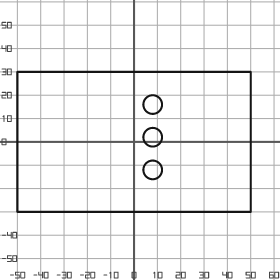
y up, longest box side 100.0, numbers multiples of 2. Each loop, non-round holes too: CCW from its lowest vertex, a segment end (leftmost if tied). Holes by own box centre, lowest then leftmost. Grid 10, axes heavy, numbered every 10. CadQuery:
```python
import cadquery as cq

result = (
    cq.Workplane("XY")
    .moveTo(-50.0, -30.0)
    .lineTo(50.0, -30.0)
    .lineTo(50.0, 30.0)
    .lineTo(-50.0, 30.0)
    .close()
    .moveTo(8.0, -12.0)
    .circle(4.0)
    .moveTo(8.0, 2.0)
    .circle(4.0)
    .moveTo(8.0, 16.0)
    .circle(4.0)
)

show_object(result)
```